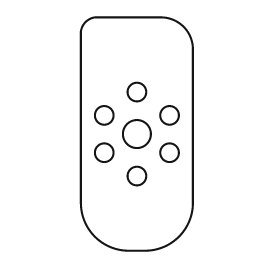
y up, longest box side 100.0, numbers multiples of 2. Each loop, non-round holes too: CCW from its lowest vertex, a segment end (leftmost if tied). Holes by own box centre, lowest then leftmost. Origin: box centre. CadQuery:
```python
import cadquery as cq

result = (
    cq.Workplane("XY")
    .moveTo(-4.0, -50.0)
    .lineTo(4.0, -50.0)
    .threePointArc((18.0, -44.0), (24.0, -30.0))
    .lineTo(24.0, 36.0)
    .threePointArc((20.0, 46.0), (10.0, 50.0))
    .lineTo(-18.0, 50.0)
    .threePointArc((-22.0, 48.0), (-24.0, 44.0))
    .lineTo(-24.0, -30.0)
    .threePointArc((-18.0, -44.0), (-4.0, -50.0))
    .close()
    .moveTo(0.0, -18.0)
    .circle(4.0)
    .moveTo(-14.0, -8.0)
    .circle(4.0)
    .moveTo(14.0, -8.0)
    .circle(4.0)
    .moveTo(0.0, 0.0)
    .circle(6.0)
    .moveTo(-14.0, 8.0)
    .circle(4.0)
    .moveTo(14.0, 8.0)
    .circle(4.0)
    .moveTo(0.0, 18.0)
    .circle(4.0)
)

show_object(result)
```